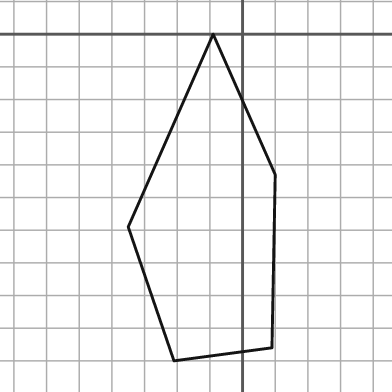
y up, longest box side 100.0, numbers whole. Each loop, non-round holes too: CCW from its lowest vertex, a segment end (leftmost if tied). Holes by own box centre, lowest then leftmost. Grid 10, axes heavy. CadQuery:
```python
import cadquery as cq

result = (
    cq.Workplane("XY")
    .moveTo(-21.0, -100.0)
    .lineTo(9.0, -96.0)
    .lineTo(10.0, -43.0)
    .lineTo(-9.0, 0.0)
    .lineTo(-35.0, -59.0)
    .close()
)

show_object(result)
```